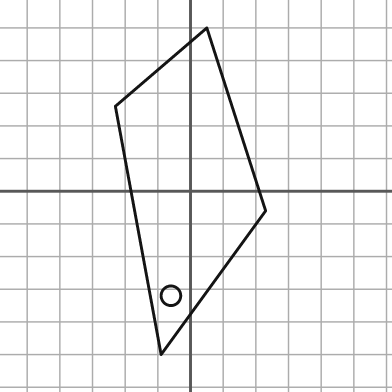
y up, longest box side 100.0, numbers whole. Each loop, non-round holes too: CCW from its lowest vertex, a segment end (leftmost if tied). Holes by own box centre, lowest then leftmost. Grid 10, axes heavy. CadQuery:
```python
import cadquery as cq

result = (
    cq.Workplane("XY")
    .moveTo(-9.0, -50.0)
    .lineTo(23.0, -6.0)
    .lineTo(5.0, 50.0)
    .lineTo(-23.0, 26.0)
    .close()
    .moveTo(-6.0, -32.0)
    .circle(3.0)
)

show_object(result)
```